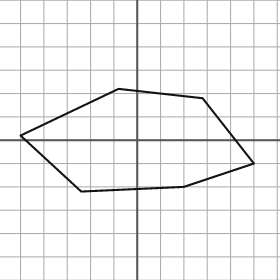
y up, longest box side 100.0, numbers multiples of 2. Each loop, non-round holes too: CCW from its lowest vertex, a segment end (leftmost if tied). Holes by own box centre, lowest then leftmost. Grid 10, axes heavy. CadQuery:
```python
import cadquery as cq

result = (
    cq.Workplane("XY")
    .moveTo(-24.0, -22.0)
    .lineTo(20.0, -20.0)
    .lineTo(50.0, -10.0)
    .lineTo(28.0, 18.0)
    .lineTo(-8.0, 22.0)
    .lineTo(-50.0, 2.0)
    .close()
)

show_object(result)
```